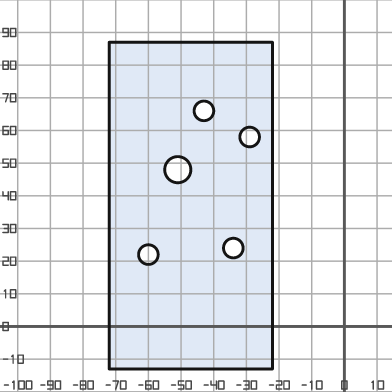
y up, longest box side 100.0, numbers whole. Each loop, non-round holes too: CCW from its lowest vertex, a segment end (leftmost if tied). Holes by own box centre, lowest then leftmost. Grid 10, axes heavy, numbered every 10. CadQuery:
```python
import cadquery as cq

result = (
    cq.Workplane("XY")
    .moveTo(-72.0, -13.0)
    .lineTo(-22.0, -13.0)
    .lineTo(-22.0, 87.0)
    .lineTo(-72.0, 87.0)
    .close()
    .moveTo(-60.0, 22.0)
    .circle(3.0)
    .moveTo(-34.0, 24.0)
    .circle(3.0)
    .moveTo(-51.0, 48.0)
    .circle(4.0)
    .moveTo(-29.0, 58.0)
    .circle(3.0)
    .moveTo(-43.0, 66.0)
    .circle(3.0)
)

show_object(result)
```